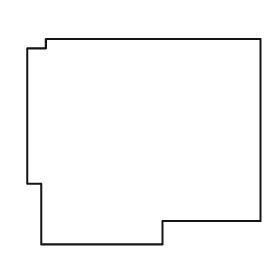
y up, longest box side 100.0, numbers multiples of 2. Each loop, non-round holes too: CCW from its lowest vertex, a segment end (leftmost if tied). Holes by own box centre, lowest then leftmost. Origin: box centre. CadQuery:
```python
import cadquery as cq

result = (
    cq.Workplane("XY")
    .moveTo(-44.0, -44.0)
    .lineTo(8.0, -44.0)
    .lineTo(8.0, -34.0)
    .lineTo(50.0, -34.0)
    .lineTo(50.0, 44.0)
    .lineTo(-42.0, 44.0)
    .lineTo(-42.0, 40.0)
    .lineTo(-50.0, 40.0)
    .lineTo(-50.0, -18.0)
    .lineTo(-44.0, -18.0)
    .close()
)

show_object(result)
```